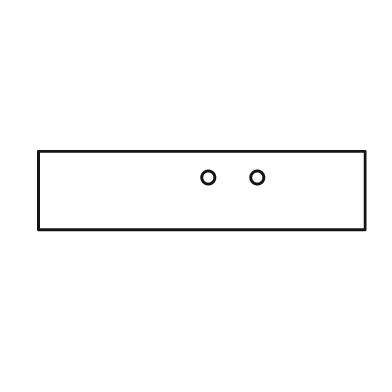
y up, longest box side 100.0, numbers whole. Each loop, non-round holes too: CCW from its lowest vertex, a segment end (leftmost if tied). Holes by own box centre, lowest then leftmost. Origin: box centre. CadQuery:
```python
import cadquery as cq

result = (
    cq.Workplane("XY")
    .moveTo(-50.0, -12.0)
    .lineTo(50.0, -12.0)
    .lineTo(50.0, 12.0)
    .lineTo(-50.0, 12.0)
    .close()
    .moveTo(2.0, 4.0)
    .circle(2.0)
    .moveTo(17.0, 4.0)
    .circle(2.0)
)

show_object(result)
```